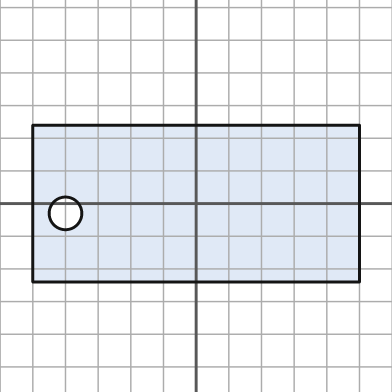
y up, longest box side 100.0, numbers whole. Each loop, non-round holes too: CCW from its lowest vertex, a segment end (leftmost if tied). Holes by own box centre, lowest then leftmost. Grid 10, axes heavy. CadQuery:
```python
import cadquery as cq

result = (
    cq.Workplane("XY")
    .moveTo(-50.0, -24.0)
    .lineTo(50.0, -24.0)
    .lineTo(50.0, 24.0)
    .lineTo(-50.0, 24.0)
    .close()
    .moveTo(-40.0, -3.0)
    .circle(5.0)
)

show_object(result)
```